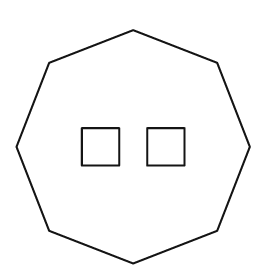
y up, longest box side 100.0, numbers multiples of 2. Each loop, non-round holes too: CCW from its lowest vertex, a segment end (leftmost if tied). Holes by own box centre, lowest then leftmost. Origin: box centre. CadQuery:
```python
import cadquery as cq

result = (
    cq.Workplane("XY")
    .moveTo(0.0, -50.0)
    .lineTo(36.0, -36.0)
    .lineTo(50.0, 0.0)
    .lineTo(36.0, 36.0)
    .lineTo(0.0, 50.0)
    .lineTo(-36.0, 36.0)
    .lineTo(-50.0, 0.0)
    .lineTo(-36.0, -36.0)
    .close()
    .moveTo(-22.0, -8.0)
    .lineTo(-6.0, -8.0)
    .lineTo(-6.0, 8.0)
    .lineTo(-22.0, 8.0)
    .close()
    .moveTo(6.0, -8.0)
    .lineTo(22.0, -8.0)
    .lineTo(22.0, 8.0)
    .lineTo(6.0, 8.0)
    .close()
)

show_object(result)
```